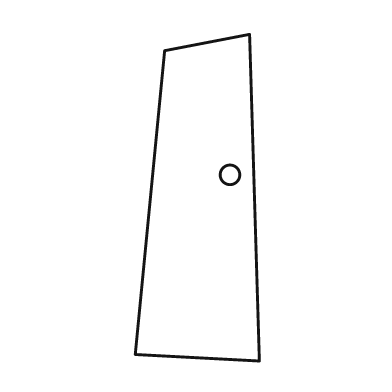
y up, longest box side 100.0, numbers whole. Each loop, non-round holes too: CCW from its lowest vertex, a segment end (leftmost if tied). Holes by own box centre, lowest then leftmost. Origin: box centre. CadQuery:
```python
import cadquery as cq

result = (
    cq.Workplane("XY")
    .moveTo(19.0, -50.0)
    .lineTo(16.0, 50.0)
    .lineTo(-10.0, 45.0)
    .lineTo(-19.0, -48.0)
    .close()
    .moveTo(10.0, 7.0)
    .circle(3.0)
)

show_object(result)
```